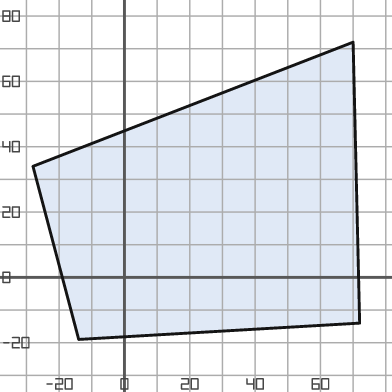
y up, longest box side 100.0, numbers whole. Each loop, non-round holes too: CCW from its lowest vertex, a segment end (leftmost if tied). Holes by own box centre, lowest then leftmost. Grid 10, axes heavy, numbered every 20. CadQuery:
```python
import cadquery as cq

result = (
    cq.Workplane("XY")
    .moveTo(-14.0, -19.0)
    .lineTo(72.0, -14.0)
    .lineTo(70.0, 72.0)
    .lineTo(-28.0, 34.0)
    .close()
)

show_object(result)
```